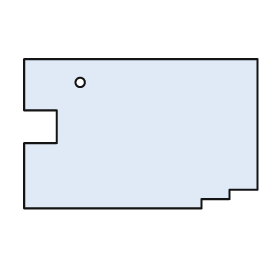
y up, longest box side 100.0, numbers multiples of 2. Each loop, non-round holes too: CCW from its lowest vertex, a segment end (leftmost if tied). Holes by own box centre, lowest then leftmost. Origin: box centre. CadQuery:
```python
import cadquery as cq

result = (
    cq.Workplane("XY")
    .moveTo(-50.0, -32.0)
    .lineTo(26.0, -32.0)
    .lineTo(26.0, -28.0)
    .lineTo(38.0, -28.0)
    .lineTo(38.0, -24.0)
    .lineTo(50.0, -24.0)
    .lineTo(50.0, 32.0)
    .lineTo(-50.0, 32.0)
    .lineTo(-50.0, 10.0)
    .lineTo(-36.0, 10.0)
    .lineTo(-36.0, -4.0)
    .lineTo(-50.0, -4.0)
    .close()
    .moveTo(-26.0, 22.0)
    .circle(2.0)
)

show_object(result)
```